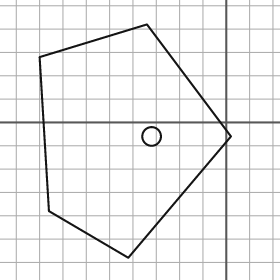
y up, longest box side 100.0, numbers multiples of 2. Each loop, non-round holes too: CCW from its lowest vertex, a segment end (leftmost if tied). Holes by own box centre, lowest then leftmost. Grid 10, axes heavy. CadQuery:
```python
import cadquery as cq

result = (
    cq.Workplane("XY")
    .moveTo(-42.0, -58.0)
    .lineTo(2.0, -6.0)
    .lineTo(-34.0, 42.0)
    .lineTo(-80.0, 28.0)
    .lineTo(-76.0, -38.0)
    .close()
    .moveTo(-32.0, -6.0)
    .circle(4.0)
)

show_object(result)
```